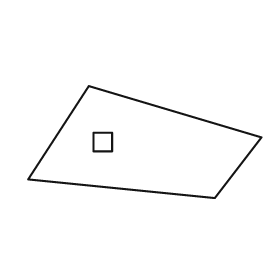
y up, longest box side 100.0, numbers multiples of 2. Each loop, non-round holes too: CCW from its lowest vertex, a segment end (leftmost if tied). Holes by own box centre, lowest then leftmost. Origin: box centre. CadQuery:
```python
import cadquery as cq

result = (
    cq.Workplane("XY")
    .moveTo(30.0, -24.0)
    .lineTo(50.0, 2.0)
    .lineTo(-24.0, 24.0)
    .lineTo(-50.0, -16.0)
    .close()
    .moveTo(-22.0, -4.0)
    .lineTo(-14.0, -4.0)
    .lineTo(-14.0, 4.0)
    .lineTo(-22.0, 4.0)
    .close()
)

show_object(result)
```